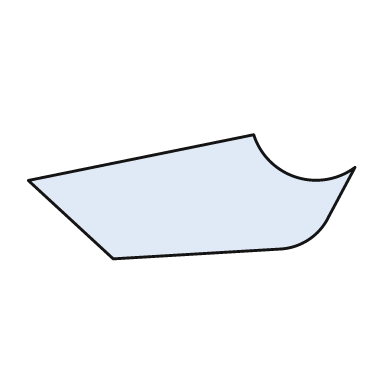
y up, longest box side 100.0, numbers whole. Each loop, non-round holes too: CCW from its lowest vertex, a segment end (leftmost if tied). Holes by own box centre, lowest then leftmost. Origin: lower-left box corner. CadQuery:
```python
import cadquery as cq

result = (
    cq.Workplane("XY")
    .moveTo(26.0, 0.0)
    .lineTo(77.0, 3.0)
    .threePointArc((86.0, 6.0), (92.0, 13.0))
    .lineTo(100.0, 28.0)
    .threePointArc((82.0, 25.0), (69.0, 38.0))
    .lineTo(0.0, 24.0)
    .close()
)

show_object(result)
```